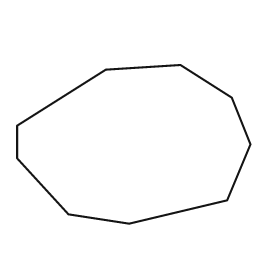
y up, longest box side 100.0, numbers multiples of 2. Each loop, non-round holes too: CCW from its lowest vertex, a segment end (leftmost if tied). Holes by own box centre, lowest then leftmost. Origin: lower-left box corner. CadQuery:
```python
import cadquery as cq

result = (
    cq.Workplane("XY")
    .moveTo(48.0, 0.0)
    .lineTo(90.0, 10.0)
    .lineTo(100.0, 34.0)
    .lineTo(92.0, 54.0)
    .lineTo(70.0, 68.0)
    .lineTo(38.0, 66.0)
    .lineTo(0.0, 42.0)
    .lineTo(0.0, 28.0)
    .lineTo(22.0, 4.0)
    .close()
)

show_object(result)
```